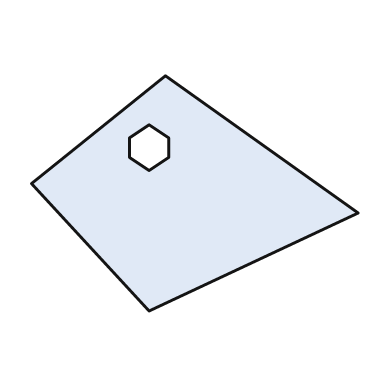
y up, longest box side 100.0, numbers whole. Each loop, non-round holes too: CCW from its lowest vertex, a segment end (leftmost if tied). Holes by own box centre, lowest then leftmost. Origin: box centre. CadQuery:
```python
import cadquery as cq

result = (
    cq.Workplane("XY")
    .moveTo(-14.0, -36.0)
    .lineTo(50.0, -6.0)
    .lineTo(-9.0, 36.0)
    .lineTo(-50.0, 3.0)
    .close()
    .moveTo(-14.0, 7.0)
    .lineTo(-8.0, 11.0)
    .lineTo(-8.0, 17.0)
    .lineTo(-14.0, 21.0)
    .lineTo(-20.0, 17.0)
    .lineTo(-20.0, 11.0)
    .close()
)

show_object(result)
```